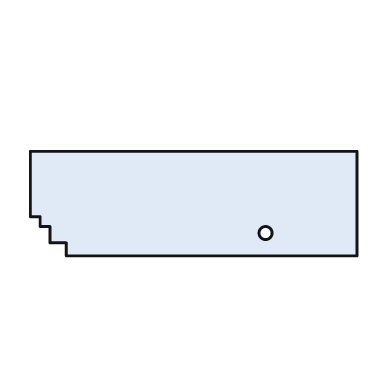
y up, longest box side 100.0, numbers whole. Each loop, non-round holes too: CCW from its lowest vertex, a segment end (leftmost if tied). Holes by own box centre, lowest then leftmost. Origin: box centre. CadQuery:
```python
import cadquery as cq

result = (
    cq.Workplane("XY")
    .moveTo(-39.0, -16.0)
    .lineTo(50.0, -16.0)
    .lineTo(50.0, 16.0)
    .lineTo(-50.0, 16.0)
    .lineTo(-50.0, -4.0)
    .lineTo(-47.0, -4.0)
    .lineTo(-47.0, -7.0)
    .lineTo(-44.0, -7.0)
    .lineTo(-44.0, -12.0)
    .lineTo(-39.0, -12.0)
    .close()
    .moveTo(22.0, -9.0)
    .circle(2.0)
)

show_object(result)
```